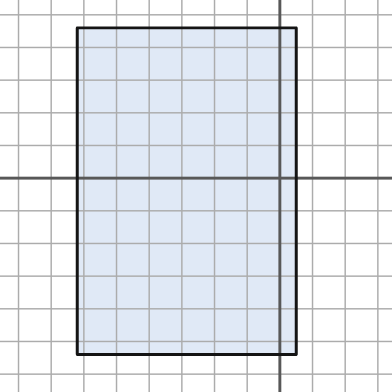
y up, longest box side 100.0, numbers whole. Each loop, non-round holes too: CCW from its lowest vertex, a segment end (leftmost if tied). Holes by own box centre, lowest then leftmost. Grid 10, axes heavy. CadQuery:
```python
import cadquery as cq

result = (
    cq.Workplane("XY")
    .moveTo(-62.0, -54.0)
    .lineTo(5.0, -54.0)
    .lineTo(5.0, 46.0)
    .lineTo(-62.0, 46.0)
    .close()
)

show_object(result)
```